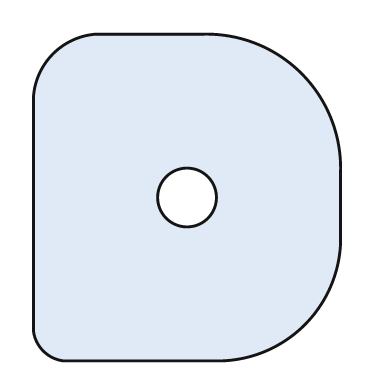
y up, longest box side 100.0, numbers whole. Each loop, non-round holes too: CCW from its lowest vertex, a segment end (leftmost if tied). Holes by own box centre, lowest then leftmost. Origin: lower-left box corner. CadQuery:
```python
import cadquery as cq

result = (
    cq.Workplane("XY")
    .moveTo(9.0, 0.0)
    .lineTo(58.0, 0.0)
    .threePointArc((83.0, 11.0), (94.0, 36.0))
    .lineTo(94.0, 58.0)
    .threePointArc((82.0, 88.0), (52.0, 100.0))
    .lineTo(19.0, 100.0)
    .threePointArc((6.0, 94.0), (0.0, 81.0))
    .lineTo(0.0, 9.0)
    .threePointArc((3.0, 3.0), (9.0, 0.0))
    .close()
    .moveTo(47.0, 50.0)
    .circle(9.0)
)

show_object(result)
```